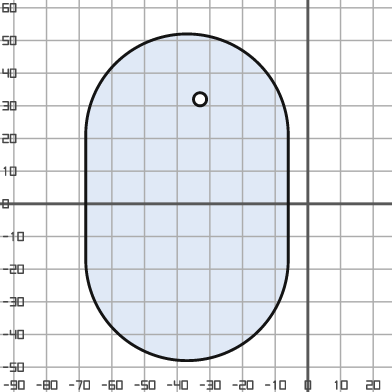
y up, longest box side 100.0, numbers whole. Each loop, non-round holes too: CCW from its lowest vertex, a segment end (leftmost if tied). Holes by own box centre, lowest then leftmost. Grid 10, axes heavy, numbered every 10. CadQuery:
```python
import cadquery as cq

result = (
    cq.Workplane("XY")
    .moveTo(-68.0, -17.0)
    .threePointArc((-37.0, -48.0), (-6.0, -17.0))
    .lineTo(-6.0, 21.0)
    .threePointArc((-37.0, 52.0), (-68.0, 21.0))
    .close()
    .moveTo(-33.0, 32.0)
    .circle(2.0)
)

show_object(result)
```